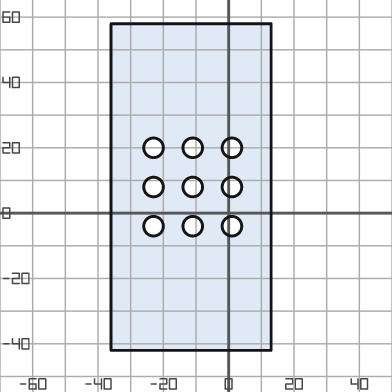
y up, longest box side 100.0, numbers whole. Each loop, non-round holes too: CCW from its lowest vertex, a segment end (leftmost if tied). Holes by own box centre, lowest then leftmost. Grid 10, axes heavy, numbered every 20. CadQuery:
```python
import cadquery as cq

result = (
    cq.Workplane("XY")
    .moveTo(-36.0, -42.0)
    .lineTo(13.0, -42.0)
    .lineTo(13.0, 58.0)
    .lineTo(-36.0, 58.0)
    .close()
    .moveTo(-23.0, -4.0)
    .circle(3.0)
    .moveTo(-11.0, -4.0)
    .circle(3.0)
    .moveTo(1.0, -4.0)
    .circle(3.0)
    .moveTo(-23.0, 8.0)
    .circle(3.0)
    .moveTo(-11.0, 8.0)
    .circle(3.0)
    .moveTo(1.0, 8.0)
    .circle(3.0)
    .moveTo(-23.0, 20.0)
    .circle(3.0)
    .moveTo(-11.0, 20.0)
    .circle(3.0)
    .moveTo(1.0, 20.0)
    .circle(3.0)
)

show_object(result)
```